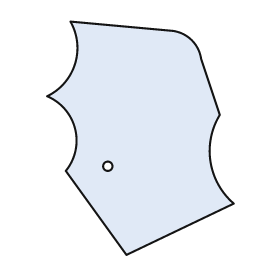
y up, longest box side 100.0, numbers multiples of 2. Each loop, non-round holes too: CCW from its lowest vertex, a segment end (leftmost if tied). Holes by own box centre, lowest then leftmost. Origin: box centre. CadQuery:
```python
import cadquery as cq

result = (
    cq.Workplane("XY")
    .moveTo(-6.0, -50.0)
    .lineTo(40.0, -28.0)
    .threePointArc((30.0, -10.0), (34.0, 10.0))
    .lineTo(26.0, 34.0)
    .threePointArc((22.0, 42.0), (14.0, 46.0))
    .lineTo(-30.0, 50.0)
    .threePointArc((-28.0, 32.0), (-40.0, 18.0))
    .threePointArc((-28.0, 4.0), (-32.0, -14.0))
    .close()
    .moveTo(-14.0, -12.0)
    .circle(2.0)
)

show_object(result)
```